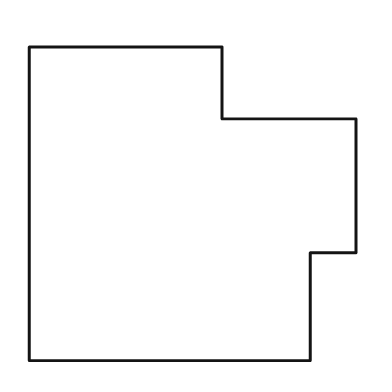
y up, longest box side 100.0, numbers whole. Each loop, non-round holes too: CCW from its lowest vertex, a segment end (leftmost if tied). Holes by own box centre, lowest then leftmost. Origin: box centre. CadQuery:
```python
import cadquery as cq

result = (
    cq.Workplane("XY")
    .moveTo(-50.0, -48.0)
    .lineTo(36.0, -48.0)
    .lineTo(36.0, -15.0)
    .lineTo(50.0, -15.0)
    .lineTo(50.0, 26.0)
    .lineTo(9.0, 26.0)
    .lineTo(9.0, 48.0)
    .lineTo(-50.0, 48.0)
    .close()
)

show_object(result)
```